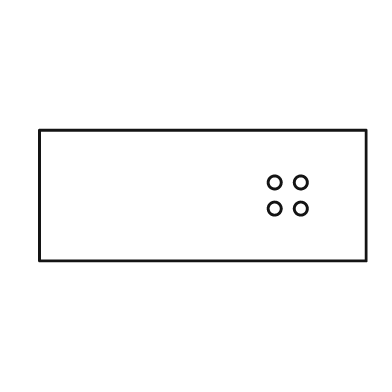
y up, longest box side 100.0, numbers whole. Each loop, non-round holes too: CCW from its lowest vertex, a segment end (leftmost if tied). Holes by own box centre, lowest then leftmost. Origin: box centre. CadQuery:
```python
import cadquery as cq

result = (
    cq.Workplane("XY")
    .moveTo(-50.0, -20.0)
    .lineTo(50.0, -20.0)
    .lineTo(50.0, 20.0)
    .lineTo(-50.0, 20.0)
    .close()
    .moveTo(22.0, -4.0)
    .circle(2.0)
    .moveTo(30.0, -4.0)
    .circle(2.0)
    .moveTo(22.0, 4.0)
    .circle(2.0)
    .moveTo(30.0, 4.0)
    .circle(2.0)
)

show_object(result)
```